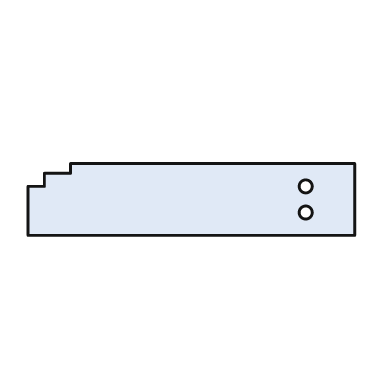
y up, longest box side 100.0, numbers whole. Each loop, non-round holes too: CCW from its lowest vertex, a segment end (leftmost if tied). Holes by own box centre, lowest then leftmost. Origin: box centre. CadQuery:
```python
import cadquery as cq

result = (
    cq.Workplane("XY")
    .moveTo(-50.0, -11.0)
    .lineTo(50.0, -11.0)
    .lineTo(50.0, 11.0)
    .lineTo(-37.0, 11.0)
    .lineTo(-37.0, 8.0)
    .lineTo(-45.0, 8.0)
    .lineTo(-45.0, 4.0)
    .lineTo(-50.0, 4.0)
    .close()
    .moveTo(35.0, -4.0)
    .circle(2.0)
    .moveTo(35.0, 4.0)
    .circle(2.0)
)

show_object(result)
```